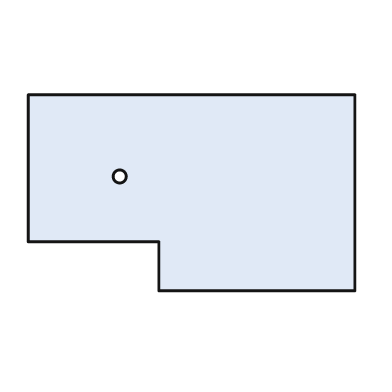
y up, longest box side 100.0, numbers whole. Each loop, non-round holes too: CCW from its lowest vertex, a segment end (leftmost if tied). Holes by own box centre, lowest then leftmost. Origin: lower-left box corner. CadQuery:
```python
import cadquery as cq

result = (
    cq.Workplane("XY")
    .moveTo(40.0, 0.0)
    .lineTo(100.0, 0.0)
    .lineTo(100.0, 60.0)
    .lineTo(0.0, 60.0)
    .lineTo(0.0, 15.0)
    .lineTo(40.0, 15.0)
    .close()
    .moveTo(28.0, 35.0)
    .circle(2.0)
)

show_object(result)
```